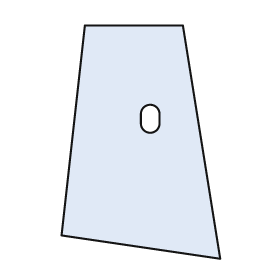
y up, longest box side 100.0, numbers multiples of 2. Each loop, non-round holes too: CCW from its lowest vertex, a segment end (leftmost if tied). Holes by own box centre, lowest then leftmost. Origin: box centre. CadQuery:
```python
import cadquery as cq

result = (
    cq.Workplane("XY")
    .moveTo(34.0, -50.0)
    .lineTo(18.0, 50.0)
    .lineTo(-24.0, 50.0)
    .lineTo(-34.0, -40.0)
    .close()
    .moveTo(0.0, 8.0)
    .threePointArc((4.0, 4.0), (8.0, 8.0))
    .lineTo(8.0, 12.0)
    .threePointArc((4.0, 16.0), (0.0, 12.0))
    .close()
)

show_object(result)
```